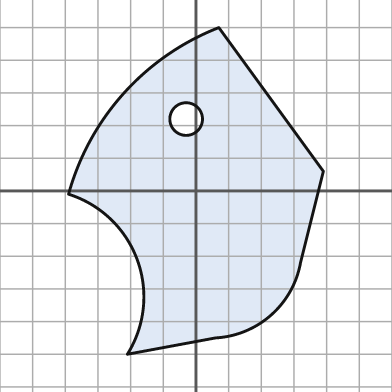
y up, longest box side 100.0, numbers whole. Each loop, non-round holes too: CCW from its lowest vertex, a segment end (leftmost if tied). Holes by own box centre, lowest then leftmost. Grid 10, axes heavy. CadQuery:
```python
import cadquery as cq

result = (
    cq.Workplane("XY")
    .moveTo(-21.0, -50.0)
    .lineTo(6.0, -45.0)
    .threePointArc((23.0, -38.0), (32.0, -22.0))
    .lineTo(39.0, 6.0)
    .lineTo(7.0, 50.0)
    .threePointArc((-22.0, 30.0), (-39.0, -1.0))
    .threePointArc((-18.0, -21.0), (-21.0, -50.0))
    .close()
    .moveTo(-3.0, 22.0)
    .circle(5.0)
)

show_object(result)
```